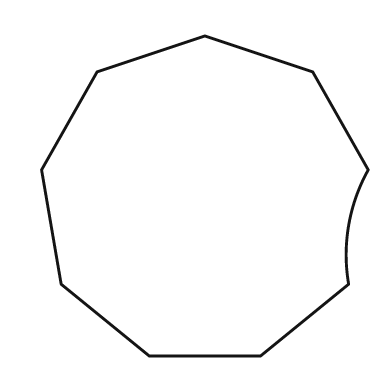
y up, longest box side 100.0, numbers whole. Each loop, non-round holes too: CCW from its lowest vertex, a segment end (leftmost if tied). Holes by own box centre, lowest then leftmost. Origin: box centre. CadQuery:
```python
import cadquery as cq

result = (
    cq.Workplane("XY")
    .moveTo(-17.0, -49.0)
    .lineTo(17.0, -49.0)
    .lineTo(44.0, -27.0)
    .threePointArc((44.0, -9.0), (50.0, 8.0))
    .lineTo(33.0, 38.0)
    .lineTo(0.0, 49.0)
    .lineTo(-33.0, 38.0)
    .lineTo(-50.0, 8.0)
    .lineTo(-44.0, -27.0)
    .close()
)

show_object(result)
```